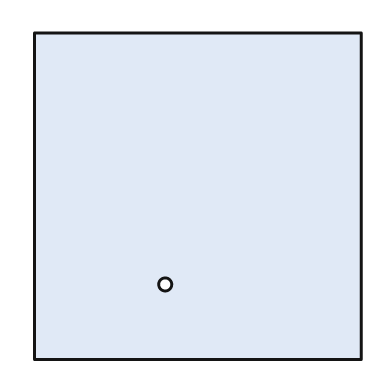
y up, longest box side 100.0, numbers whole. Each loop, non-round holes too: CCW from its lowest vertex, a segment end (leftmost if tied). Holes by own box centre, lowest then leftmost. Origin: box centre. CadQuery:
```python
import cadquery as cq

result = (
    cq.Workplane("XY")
    .moveTo(-50.0, -50.0)
    .lineTo(50.0, -50.0)
    .lineTo(50.0, 50.0)
    .lineTo(-50.0, 50.0)
    .close()
    .moveTo(-10.0, -27.0)
    .circle(2.0)
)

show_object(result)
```